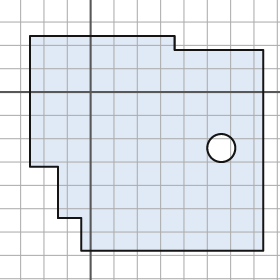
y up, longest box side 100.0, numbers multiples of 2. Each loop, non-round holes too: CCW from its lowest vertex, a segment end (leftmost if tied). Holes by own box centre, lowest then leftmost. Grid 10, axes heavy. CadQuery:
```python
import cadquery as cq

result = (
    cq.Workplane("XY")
    .moveTo(-4.0, -68.0)
    .lineTo(74.0, -68.0)
    .lineTo(74.0, 18.0)
    .lineTo(36.0, 18.0)
    .lineTo(36.0, 24.0)
    .lineTo(-26.0, 24.0)
    .lineTo(-26.0, -32.0)
    .lineTo(-14.0, -32.0)
    .lineTo(-14.0, -54.0)
    .lineTo(-4.0, -54.0)
    .close()
    .moveTo(56.0, -24.0)
    .circle(6.0)
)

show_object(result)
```